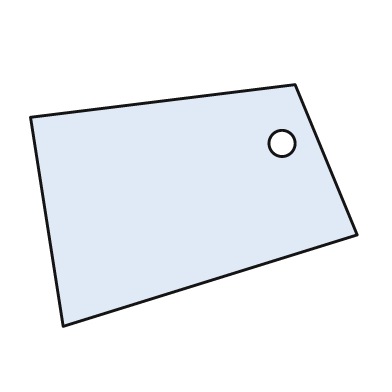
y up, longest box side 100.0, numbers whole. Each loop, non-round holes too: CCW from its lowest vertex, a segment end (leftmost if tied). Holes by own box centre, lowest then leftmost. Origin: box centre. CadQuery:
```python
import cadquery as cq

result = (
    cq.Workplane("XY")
    .moveTo(-40.0, -37.0)
    .lineTo(50.0, -9.0)
    .lineTo(31.0, 37.0)
    .lineTo(-50.0, 27.0)
    .close()
    .moveTo(27.0, 19.0)
    .circle(4.0)
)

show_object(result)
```